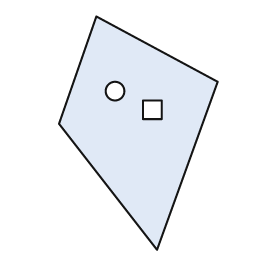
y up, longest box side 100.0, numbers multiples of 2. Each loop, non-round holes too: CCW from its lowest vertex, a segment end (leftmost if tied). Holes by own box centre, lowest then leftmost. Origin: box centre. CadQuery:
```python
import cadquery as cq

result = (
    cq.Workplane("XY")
    .moveTo(8.0, -50.0)
    .lineTo(34.0, 22.0)
    .lineTo(-18.0, 50.0)
    .lineTo(-34.0, 4.0)
    .close()
    .moveTo(2.0, 6.0)
    .lineTo(10.0, 6.0)
    .lineTo(10.0, 14.0)
    .lineTo(2.0, 14.0)
    .close()
    .moveTo(-10.0, 18.0)
    .circle(4.0)
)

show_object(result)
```